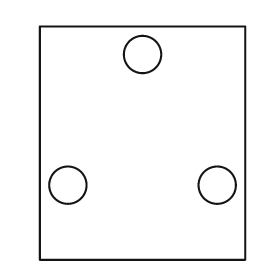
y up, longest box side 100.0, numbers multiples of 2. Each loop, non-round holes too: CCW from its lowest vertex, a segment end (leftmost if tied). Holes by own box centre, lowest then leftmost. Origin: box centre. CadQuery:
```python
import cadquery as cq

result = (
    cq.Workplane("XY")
    .moveTo(-44.0, -50.0)
    .lineTo(44.0, -50.0)
    .lineTo(44.0, 50.0)
    .lineTo(-44.0, 50.0)
    .close()
    .moveTo(-32.0, -18.0)
    .circle(8.0)
    .moveTo(32.0, -18.0)
    .circle(8.0)
    .moveTo(0.0, 38.0)
    .circle(8.0)
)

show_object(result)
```